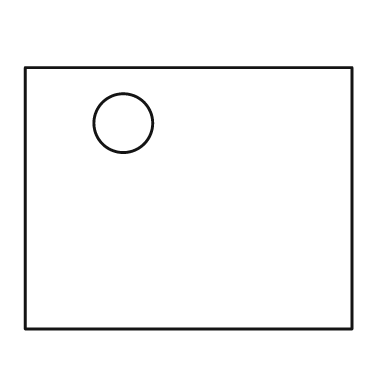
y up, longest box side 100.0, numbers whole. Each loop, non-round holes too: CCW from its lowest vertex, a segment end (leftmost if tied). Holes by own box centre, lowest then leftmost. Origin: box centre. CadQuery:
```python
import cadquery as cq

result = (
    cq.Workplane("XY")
    .moveTo(-50.0, -40.0)
    .lineTo(50.0, -40.0)
    .lineTo(50.0, 40.0)
    .lineTo(-50.0, 40.0)
    .close()
    .moveTo(-20.0, 23.0)
    .circle(9.0)
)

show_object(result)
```